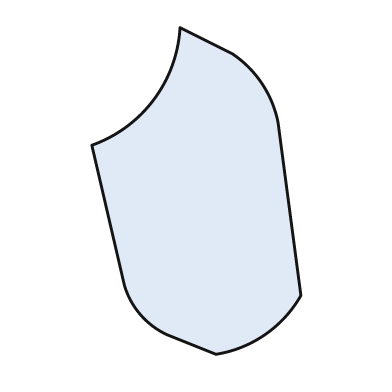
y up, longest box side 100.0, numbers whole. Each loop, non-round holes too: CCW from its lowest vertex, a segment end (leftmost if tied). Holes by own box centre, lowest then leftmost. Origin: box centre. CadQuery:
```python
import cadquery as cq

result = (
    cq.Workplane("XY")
    .moveTo(6.0, -50.0)
    .threePointArc((21.0, -44.0), (32.0, -32.0))
    .lineTo(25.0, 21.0)
    .threePointArc((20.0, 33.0), (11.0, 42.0))
    .lineTo(-5.0, 50.0)
    .threePointArc((-13.0, 28.0), (-32.0, 14.0))
    .lineTo(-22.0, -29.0)
    .threePointArc((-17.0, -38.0), (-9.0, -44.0))
    .close()
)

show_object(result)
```